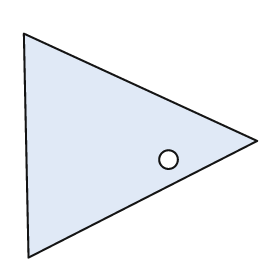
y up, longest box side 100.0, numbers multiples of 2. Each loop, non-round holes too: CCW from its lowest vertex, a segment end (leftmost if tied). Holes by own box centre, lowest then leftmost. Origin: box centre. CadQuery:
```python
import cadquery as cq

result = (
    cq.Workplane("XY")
    .moveTo(-48.0, -48.0)
    .lineTo(50.0, 2.0)
    .lineTo(-50.0, 48.0)
    .close()
    .moveTo(12.0, -6.0)
    .circle(4.0)
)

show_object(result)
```